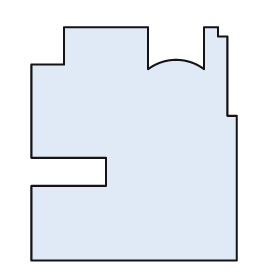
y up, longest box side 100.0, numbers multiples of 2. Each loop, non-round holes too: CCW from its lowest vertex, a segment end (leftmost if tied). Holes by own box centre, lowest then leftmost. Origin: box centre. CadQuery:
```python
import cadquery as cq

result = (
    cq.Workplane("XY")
    .moveTo(-44.0, -50.0)
    .lineTo(44.0, -50.0)
    .lineTo(44.0, 12.0)
    .lineTo(40.0, 12.0)
    .lineTo(40.0, 46.0)
    .lineTo(36.0, 46.0)
    .lineTo(36.0, 50.0)
    .lineTo(30.0, 50.0)
    .lineTo(30.0, 32.0)
    .threePointArc((18.0, 36.0), (6.0, 32.0))
    .lineTo(6.0, 50.0)
    .lineTo(-30.0, 50.0)
    .lineTo(-30.0, 34.0)
    .lineTo(-44.0, 34.0)
    .lineTo(-44.0, -6.0)
    .lineTo(-12.0, -6.0)
    .lineTo(-12.0, -18.0)
    .lineTo(-44.0, -18.0)
    .close()
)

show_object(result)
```